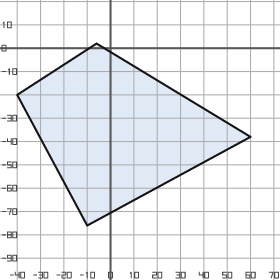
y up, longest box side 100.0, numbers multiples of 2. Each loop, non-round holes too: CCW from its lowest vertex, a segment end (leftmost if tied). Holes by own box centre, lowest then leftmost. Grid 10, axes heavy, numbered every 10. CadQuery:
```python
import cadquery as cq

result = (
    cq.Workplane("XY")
    .moveTo(-10.0, -76.0)
    .lineTo(60.0, -38.0)
    .lineTo(-6.0, 2.0)
    .lineTo(-40.0, -20.0)
    .close()
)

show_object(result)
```